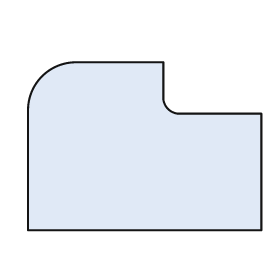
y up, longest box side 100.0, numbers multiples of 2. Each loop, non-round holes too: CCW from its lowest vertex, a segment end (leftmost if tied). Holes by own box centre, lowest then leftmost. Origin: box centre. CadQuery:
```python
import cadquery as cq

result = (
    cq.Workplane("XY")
    .moveTo(-50.0, -36.0)
    .lineTo(50.0, -36.0)
    .lineTo(50.0, 14.0)
    .lineTo(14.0, 14.0)
    .threePointArc((10.0, 16.0), (8.0, 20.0))
    .lineTo(8.0, 36.0)
    .lineTo(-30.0, 36.0)
    .threePointArc((-44.0, 30.0), (-50.0, 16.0))
    .close()
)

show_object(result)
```